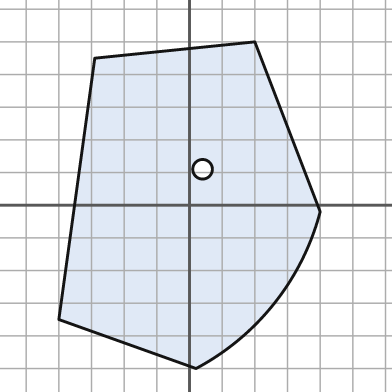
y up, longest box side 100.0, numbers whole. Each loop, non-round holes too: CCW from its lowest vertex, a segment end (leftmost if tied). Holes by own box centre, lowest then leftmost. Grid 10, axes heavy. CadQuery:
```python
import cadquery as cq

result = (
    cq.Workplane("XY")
    .moveTo(2.0, -50.0)
    .threePointArc((26.0, -30.0), (40.0, -2.0))
    .lineTo(20.0, 50.0)
    .lineTo(-29.0, 45.0)
    .lineTo(-40.0, -35.0)
    .close()
    .moveTo(4.0, 11.0)
    .circle(3.0)
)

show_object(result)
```